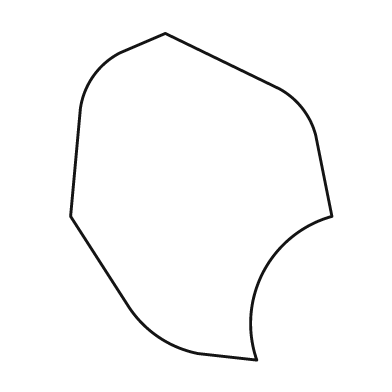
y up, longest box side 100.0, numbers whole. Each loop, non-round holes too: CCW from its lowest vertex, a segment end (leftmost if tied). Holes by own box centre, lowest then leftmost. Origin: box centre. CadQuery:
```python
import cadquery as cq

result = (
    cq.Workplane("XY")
    .moveTo(17.0, -50.0)
    .threePointArc((19.0, -23.0), (40.0, -6.0))
    .lineTo(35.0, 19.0)
    .threePointArc((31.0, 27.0), (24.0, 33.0))
    .lineTo(-11.0, 50.0)
    .lineTo(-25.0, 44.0)
    .threePointArc((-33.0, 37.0), (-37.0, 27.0))
    .lineTo(-40.0, -6.0)
    .lineTo(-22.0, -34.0)
    .threePointArc((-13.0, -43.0), (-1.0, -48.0))
    .close()
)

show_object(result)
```